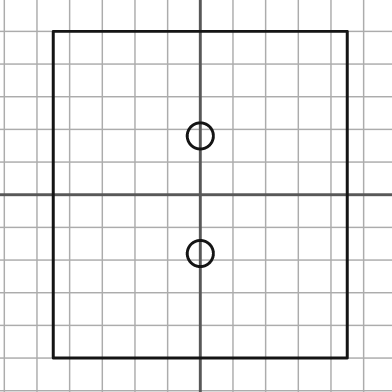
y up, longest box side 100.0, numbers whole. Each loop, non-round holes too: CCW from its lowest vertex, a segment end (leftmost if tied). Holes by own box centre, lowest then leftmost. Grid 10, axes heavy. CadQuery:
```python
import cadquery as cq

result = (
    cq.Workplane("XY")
    .moveTo(-45.0, -50.0)
    .lineTo(45.0, -50.0)
    .lineTo(45.0, 50.0)
    .lineTo(-45.0, 50.0)
    .close()
    .moveTo(0.0, -18.0)
    .circle(4.0)
    .moveTo(0.0, 18.0)
    .circle(4.0)
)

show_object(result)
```